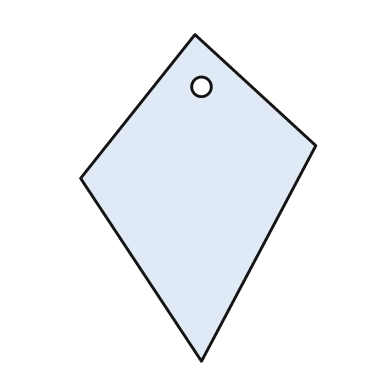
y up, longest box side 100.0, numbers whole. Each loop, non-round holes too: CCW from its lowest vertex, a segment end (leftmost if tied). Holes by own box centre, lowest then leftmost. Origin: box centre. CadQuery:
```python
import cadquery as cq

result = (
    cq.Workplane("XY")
    .moveTo(1.0, -50.0)
    .lineTo(36.0, 16.0)
    .lineTo(-1.0, 50.0)
    .lineTo(-36.0, 6.0)
    .close()
    .moveTo(1.0, 34.0)
    .circle(3.0)
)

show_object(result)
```